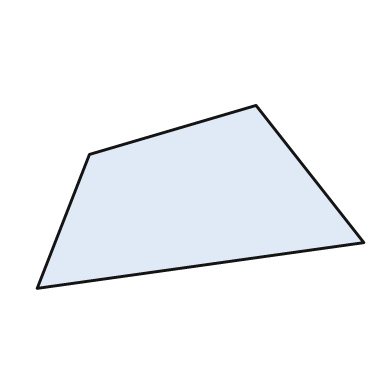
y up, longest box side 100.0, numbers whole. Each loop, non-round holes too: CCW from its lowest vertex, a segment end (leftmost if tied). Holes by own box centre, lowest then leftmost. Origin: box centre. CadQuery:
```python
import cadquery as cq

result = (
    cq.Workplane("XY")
    .moveTo(-50.0, -28.0)
    .lineTo(50.0, -14.0)
    .lineTo(17.0, 28.0)
    .lineTo(-34.0, 13.0)
    .close()
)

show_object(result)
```